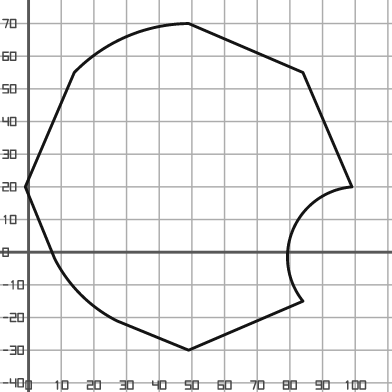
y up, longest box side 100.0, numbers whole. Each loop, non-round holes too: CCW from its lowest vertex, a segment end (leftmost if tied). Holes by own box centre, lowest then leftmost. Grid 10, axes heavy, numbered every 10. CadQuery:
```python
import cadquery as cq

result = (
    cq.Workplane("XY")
    .moveTo(49.0, -30.0)
    .lineTo(84.0, -15.0)
    .threePointArc((81.0, 7.0), (99.0, 20.0))
    .lineTo(84.0, 55.0)
    .lineTo(49.0, 70.0)
    .threePointArc((30.0, 66.0), (14.0, 55.0))
    .lineTo(-1.0, 20.0)
    .lineTo(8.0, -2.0)
    .threePointArc((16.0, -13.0), (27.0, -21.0))
    .close()
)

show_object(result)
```